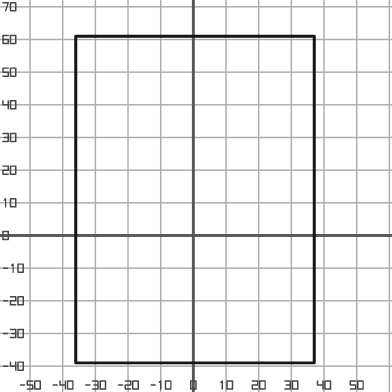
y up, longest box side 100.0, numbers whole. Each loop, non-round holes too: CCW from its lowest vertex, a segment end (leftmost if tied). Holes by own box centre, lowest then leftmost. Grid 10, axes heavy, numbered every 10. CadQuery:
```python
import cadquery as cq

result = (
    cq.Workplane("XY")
    .moveTo(-36.0, -39.0)
    .lineTo(37.0, -39.0)
    .lineTo(37.0, 61.0)
    .lineTo(-36.0, 61.0)
    .close()
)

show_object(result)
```